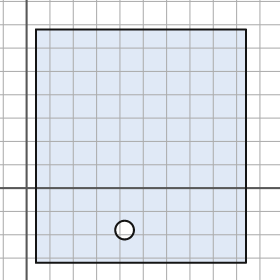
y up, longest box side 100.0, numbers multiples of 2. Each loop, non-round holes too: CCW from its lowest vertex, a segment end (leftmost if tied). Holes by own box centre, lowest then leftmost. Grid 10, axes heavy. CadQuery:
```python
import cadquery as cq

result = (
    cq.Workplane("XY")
    .moveTo(4.0, -32.0)
    .lineTo(94.0, -32.0)
    .lineTo(94.0, 68.0)
    .lineTo(4.0, 68.0)
    .close()
    .moveTo(42.0, -18.0)
    .circle(4.0)
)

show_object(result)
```